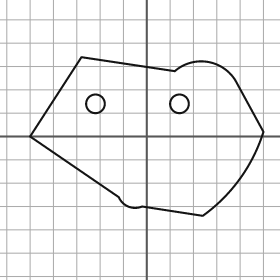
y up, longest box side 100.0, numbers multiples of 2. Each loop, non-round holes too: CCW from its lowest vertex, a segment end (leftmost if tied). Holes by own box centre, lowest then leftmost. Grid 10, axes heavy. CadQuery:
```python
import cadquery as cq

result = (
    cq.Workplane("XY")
    .moveTo(24.0, -34.0)
    .threePointArc((40.0, -18.0), (50.0, 2.0))
    .lineTo(38.0, 24.0)
    .threePointArc((26.0, 32.0), (12.0, 28.0))
    .lineTo(-28.0, 34.0)
    .lineTo(-50.0, 0.0)
    .lineTo(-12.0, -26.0)
    .threePointArc((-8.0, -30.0), (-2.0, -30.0))
    .close()
    .moveTo(-22.0, 14.0)
    .circle(4.0)
    .moveTo(14.0, 14.0)
    .circle(4.0)
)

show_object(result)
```